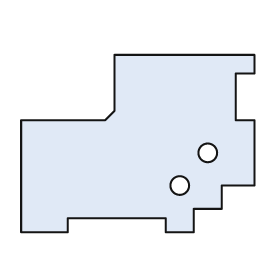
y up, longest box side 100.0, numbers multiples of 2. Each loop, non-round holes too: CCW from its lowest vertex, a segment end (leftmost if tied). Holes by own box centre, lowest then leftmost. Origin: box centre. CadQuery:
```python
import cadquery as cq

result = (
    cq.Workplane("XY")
    .moveTo(-50.0, -38.0)
    .lineTo(-30.0, -38.0)
    .lineTo(-30.0, -32.0)
    .lineTo(12.0, -32.0)
    .lineTo(12.0, -38.0)
    .lineTo(24.0, -38.0)
    .lineTo(24.0, -28.0)
    .lineTo(36.0, -28.0)
    .lineTo(36.0, -18.0)
    .lineTo(50.0, -18.0)
    .lineTo(50.0, 10.0)
    .lineTo(42.0, 10.0)
    .lineTo(42.0, 30.0)
    .lineTo(50.0, 30.0)
    .lineTo(50.0, 38.0)
    .lineTo(-10.0, 38.0)
    .lineTo(-10.0, 14.0)
    .lineTo(-14.0, 10.0)
    .lineTo(-50.0, 10.0)
    .close()
    .moveTo(18.0, -18.0)
    .circle(4.0)
    .moveTo(30.0, -4.0)
    .circle(4.0)
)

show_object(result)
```